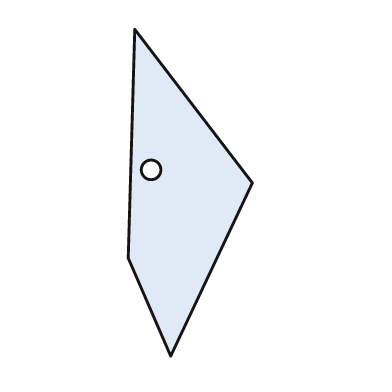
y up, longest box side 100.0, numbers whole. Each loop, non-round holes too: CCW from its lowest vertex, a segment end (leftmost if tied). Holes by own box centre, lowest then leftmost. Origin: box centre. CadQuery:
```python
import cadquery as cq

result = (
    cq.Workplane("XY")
    .moveTo(-6.0, -50.0)
    .lineTo(19.0, 3.0)
    .lineTo(-17.0, 50.0)
    .lineTo(-19.0, -20.0)
    .close()
    .moveTo(-12.0, 7.0)
    .circle(3.0)
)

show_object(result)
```